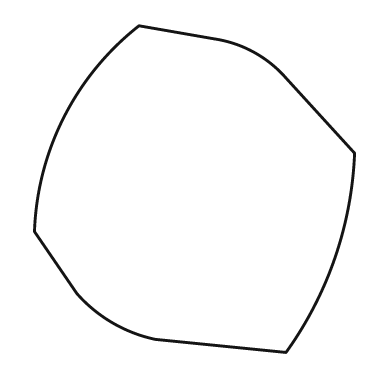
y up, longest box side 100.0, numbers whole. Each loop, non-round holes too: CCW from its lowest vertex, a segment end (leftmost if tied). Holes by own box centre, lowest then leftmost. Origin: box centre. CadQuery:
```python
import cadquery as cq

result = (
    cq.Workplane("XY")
    .moveTo(28.0, -50.0)
    .threePointArc((43.0, -21.0), (49.0, 11.0))
    .lineTo(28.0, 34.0)
    .threePointArc((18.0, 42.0), (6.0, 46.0))
    .lineTo(-17.0, 50.0)
    .threePointArc((-40.0, 22.0), (-49.0, -13.0))
    .lineTo(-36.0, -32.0)
    .threePointArc((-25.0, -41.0), (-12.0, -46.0))
    .close()
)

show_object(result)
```